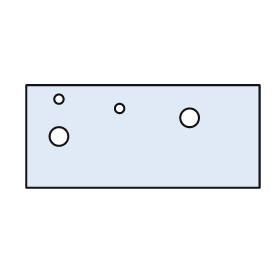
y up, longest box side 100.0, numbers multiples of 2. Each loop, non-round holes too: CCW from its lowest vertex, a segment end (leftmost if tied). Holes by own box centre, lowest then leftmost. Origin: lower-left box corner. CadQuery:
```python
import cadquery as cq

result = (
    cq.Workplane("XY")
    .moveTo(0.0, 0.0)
    .lineTo(100.0, 0.0)
    .lineTo(100.0, 44.0)
    .lineTo(0.0, 44.0)
    .close()
    .moveTo(14.0, 22.0)
    .circle(4.0)
    .moveTo(70.0, 30.0)
    .circle(4.0)
    .moveTo(40.0, 34.0)
    .circle(2.0)
    .moveTo(14.0, 38.0)
    .circle(2.0)
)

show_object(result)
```